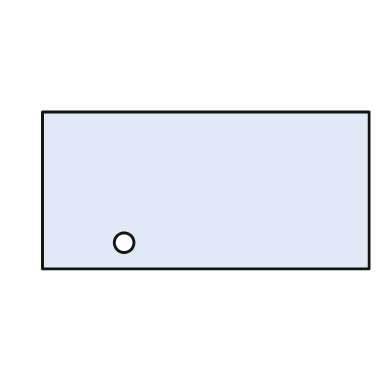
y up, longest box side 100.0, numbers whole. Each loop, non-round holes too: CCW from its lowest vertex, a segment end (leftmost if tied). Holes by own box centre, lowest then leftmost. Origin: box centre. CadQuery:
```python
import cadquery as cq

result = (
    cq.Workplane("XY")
    .moveTo(-50.0, -24.0)
    .lineTo(50.0, -24.0)
    .lineTo(50.0, 24.0)
    .lineTo(-50.0, 24.0)
    .close()
    .moveTo(-25.0, -16.0)
    .circle(3.0)
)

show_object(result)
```